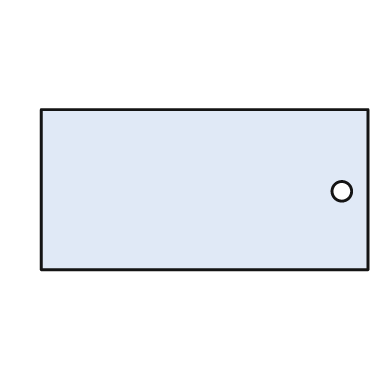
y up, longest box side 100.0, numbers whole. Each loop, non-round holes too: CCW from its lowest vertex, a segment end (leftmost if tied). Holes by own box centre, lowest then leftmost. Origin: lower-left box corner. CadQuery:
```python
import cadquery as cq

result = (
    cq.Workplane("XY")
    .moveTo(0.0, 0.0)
    .lineTo(100.0, 0.0)
    .lineTo(100.0, 49.0)
    .lineTo(0.0, 49.0)
    .close()
    .moveTo(92.0, 24.0)
    .circle(3.0)
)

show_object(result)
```